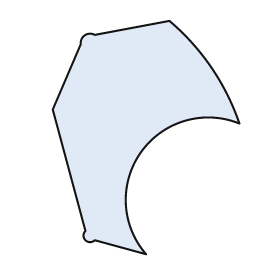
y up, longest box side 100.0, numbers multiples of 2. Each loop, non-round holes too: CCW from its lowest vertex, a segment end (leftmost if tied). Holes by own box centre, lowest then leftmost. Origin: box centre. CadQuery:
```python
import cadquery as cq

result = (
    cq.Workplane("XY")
    .moveTo(0.0, -50.0)
    .threePointArc((-2.0, -6.0), (40.0, 6.0))
    .threePointArc((28.0, 30.0), (10.0, 50.0))
    .lineTo(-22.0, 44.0)
    .threePointArc((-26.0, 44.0), (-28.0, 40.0))
    .lineTo(-40.0, 12.0)
    .lineTo(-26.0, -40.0)
    .threePointArc((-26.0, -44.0), (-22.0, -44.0))
    .close()
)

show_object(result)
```